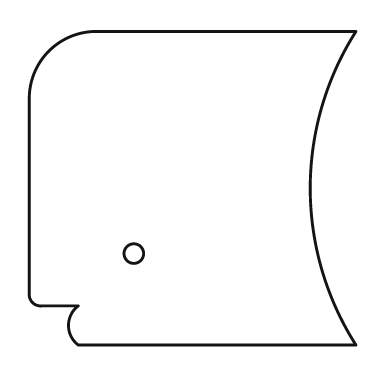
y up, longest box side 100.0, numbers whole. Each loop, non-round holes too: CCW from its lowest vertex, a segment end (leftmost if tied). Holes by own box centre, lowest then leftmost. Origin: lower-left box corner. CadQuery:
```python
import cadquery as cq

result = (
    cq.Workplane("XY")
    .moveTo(15.0, 0.0)
    .lineTo(100.0, 0.0)
    .threePointArc((86.0, 48.0), (100.0, 96.0))
    .lineTo(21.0, 96.0)
    .threePointArc((6.0, 90.0), (0.0, 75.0))
    .lineTo(0.0, 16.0)
    .threePointArc((1.0, 13.0), (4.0, 12.0))
    .lineTo(15.0, 12.0)
    .threePointArc((12.0, 6.0), (15.0, 0.0))
    .close()
    .moveTo(32.0, 28.0)
    .circle(3.0)
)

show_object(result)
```